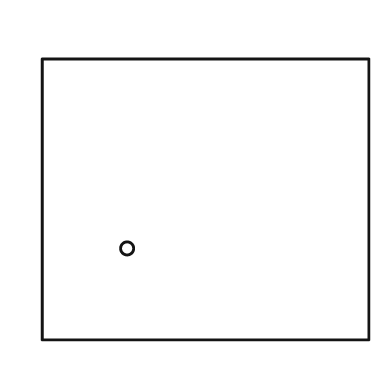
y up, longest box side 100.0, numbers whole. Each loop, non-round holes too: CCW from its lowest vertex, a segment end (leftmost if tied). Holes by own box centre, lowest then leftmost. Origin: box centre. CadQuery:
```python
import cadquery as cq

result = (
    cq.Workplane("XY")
    .moveTo(-50.0, -43.0)
    .lineTo(50.0, -43.0)
    .lineTo(50.0, 43.0)
    .lineTo(-50.0, 43.0)
    .close()
    .moveTo(-24.0, -15.0)
    .circle(2.0)
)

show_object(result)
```